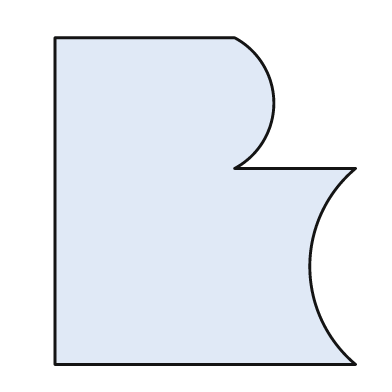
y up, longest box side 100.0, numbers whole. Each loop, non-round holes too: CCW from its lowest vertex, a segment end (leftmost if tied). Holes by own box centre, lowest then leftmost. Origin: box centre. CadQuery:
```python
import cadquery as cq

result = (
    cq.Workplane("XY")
    .moveTo(-46.0, -50.0)
    .lineTo(46.0, -50.0)
    .threePointArc((32.0, -20.0), (46.0, 10.0))
    .lineTo(9.0, 10.0)
    .threePointArc((21.0, 30.0), (9.0, 50.0))
    .lineTo(-46.0, 50.0)
    .close()
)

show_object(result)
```